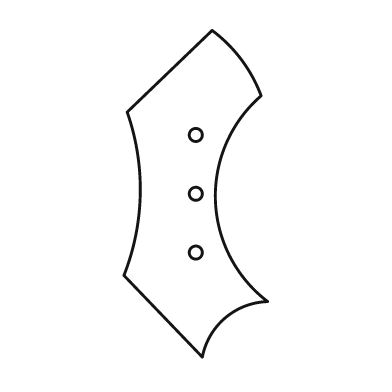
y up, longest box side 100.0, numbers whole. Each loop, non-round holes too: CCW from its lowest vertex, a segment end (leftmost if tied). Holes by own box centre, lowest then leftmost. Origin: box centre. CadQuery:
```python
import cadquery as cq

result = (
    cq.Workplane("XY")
    .moveTo(2.0, -50.0)
    .threePointArc((9.0, -38.0), (22.0, -33.0))
    .threePointArc((6.0, -2.0), (20.0, 30.0))
    .threePointArc((14.0, 41.0), (5.0, 50.0))
    .lineTo(-21.0, 25.0)
    .threePointArc((-17.0, 0.0), (-22.0, -25.0))
    .close()
    .moveTo(0.0, -18.0)
    .circle(2.0)
    .moveTo(0.0, 0.0)
    .circle(2.0)
    .moveTo(0.0, 18.0)
    .circle(2.0)
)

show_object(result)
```